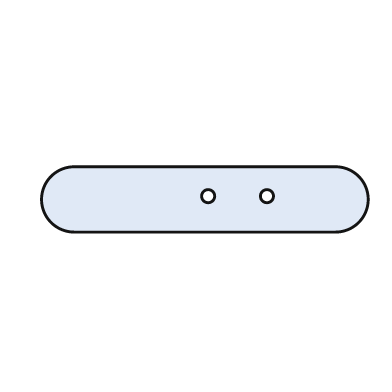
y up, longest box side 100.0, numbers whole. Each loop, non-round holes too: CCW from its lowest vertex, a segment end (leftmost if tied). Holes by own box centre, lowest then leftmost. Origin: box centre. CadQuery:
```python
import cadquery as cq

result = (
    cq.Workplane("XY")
    .moveTo(-40.0, -10.0)
    .lineTo(40.0, -10.0)
    .threePointArc((50.0, 0.0), (40.0, 10.0))
    .lineTo(-40.0, 10.0)
    .threePointArc((-50.0, 0.0), (-40.0, -10.0))
    .close()
    .moveTo(1.0, 1.0)
    .circle(2.0)
    .moveTo(19.0, 1.0)
    .circle(2.0)
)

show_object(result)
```